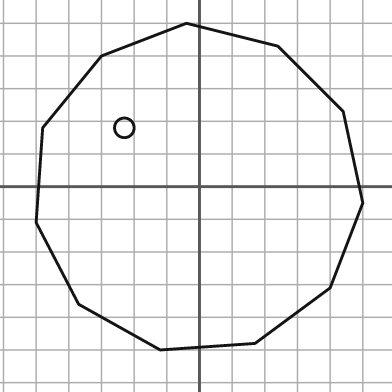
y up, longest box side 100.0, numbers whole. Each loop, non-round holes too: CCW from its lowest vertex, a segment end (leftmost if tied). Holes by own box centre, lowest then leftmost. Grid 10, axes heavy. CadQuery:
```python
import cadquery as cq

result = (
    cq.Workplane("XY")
    .moveTo(-12.0, -50.0)
    .lineTo(17.0, -48.0)
    .lineTo(40.0, -31.0)
    .lineTo(50.0, -5.0)
    .lineTo(44.0, 23.0)
    .lineTo(24.0, 43.0)
    .lineTo(-4.0, 50.0)
    .lineTo(-30.0, 40.0)
    .lineTo(-48.0, 18.0)
    .lineTo(-50.0, -11.0)
    .lineTo(-37.0, -36.0)
    .close()
    .moveTo(-23.0, 18.0)
    .circle(3.0)
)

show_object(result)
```